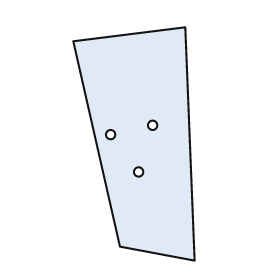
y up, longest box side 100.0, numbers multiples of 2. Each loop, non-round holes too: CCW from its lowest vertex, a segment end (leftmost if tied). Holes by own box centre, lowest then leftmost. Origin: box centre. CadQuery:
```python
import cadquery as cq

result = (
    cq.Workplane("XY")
    .moveTo(26.0, -50.0)
    .lineTo(22.0, 50.0)
    .lineTo(-26.0, 44.0)
    .lineTo(-6.0, -44.0)
    .close()
    .moveTo(2.0, -12.0)
    .circle(2.0)
    .moveTo(-10.0, 4.0)
    .circle(2.0)
    .moveTo(8.0, 8.0)
    .circle(2.0)
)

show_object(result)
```